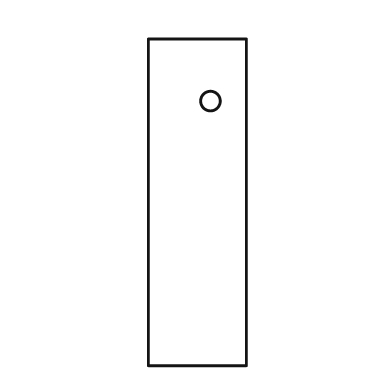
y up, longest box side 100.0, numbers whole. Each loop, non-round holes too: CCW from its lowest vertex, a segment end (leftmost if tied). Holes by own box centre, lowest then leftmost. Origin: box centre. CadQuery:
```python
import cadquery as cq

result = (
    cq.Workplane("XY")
    .moveTo(-15.0, -50.0)
    .lineTo(15.0, -50.0)
    .lineTo(15.0, 50.0)
    .lineTo(-15.0, 50.0)
    .close()
    .moveTo(4.0, 31.0)
    .circle(3.0)
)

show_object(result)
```